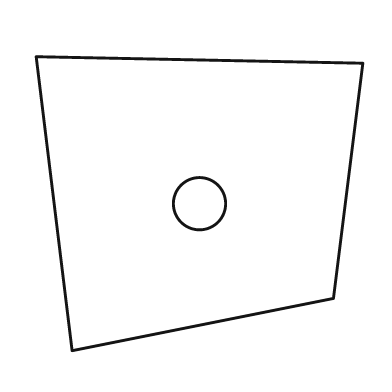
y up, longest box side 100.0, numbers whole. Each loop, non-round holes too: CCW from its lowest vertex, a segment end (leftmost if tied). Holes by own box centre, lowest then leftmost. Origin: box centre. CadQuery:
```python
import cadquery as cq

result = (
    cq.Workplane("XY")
    .moveTo(-39.0, -45.0)
    .lineTo(41.0, -29.0)
    .lineTo(50.0, 43.0)
    .lineTo(-50.0, 45.0)
    .close()
    .moveTo(0.0, 0.0)
    .circle(8.0)
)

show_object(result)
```